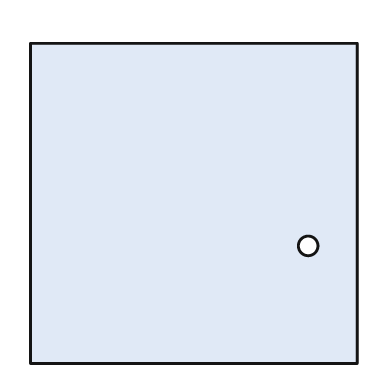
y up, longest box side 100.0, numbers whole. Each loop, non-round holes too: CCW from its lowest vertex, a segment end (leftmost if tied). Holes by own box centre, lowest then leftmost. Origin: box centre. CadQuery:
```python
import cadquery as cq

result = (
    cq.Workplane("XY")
    .moveTo(-50.0, -49.0)
    .lineTo(50.0, -49.0)
    .lineTo(50.0, 49.0)
    .lineTo(-50.0, 49.0)
    .close()
    .moveTo(35.0, -13.0)
    .circle(3.0)
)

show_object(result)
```